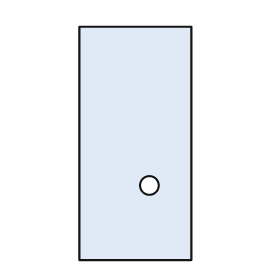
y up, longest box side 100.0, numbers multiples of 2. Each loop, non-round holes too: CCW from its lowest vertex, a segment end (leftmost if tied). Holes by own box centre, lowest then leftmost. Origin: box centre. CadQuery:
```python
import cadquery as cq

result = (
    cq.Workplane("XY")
    .moveTo(-24.0, -50.0)
    .lineTo(24.0, -50.0)
    .lineTo(24.0, 50.0)
    .lineTo(-24.0, 50.0)
    .close()
    .moveTo(6.0, -18.0)
    .circle(4.0)
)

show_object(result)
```